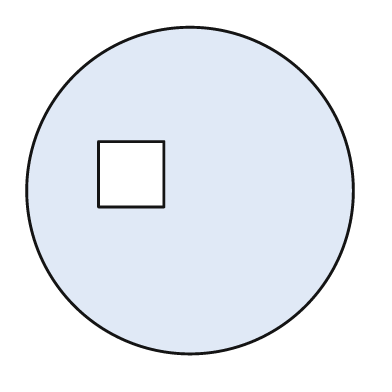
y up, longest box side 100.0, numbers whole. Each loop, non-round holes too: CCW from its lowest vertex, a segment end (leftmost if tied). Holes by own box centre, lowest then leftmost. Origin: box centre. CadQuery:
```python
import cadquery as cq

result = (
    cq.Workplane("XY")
    .moveTo(0.0, 0.0)
    .circle(50.0)
    .moveTo(-28.0, -5.0)
    .lineTo(-8.0, -5.0)
    .lineTo(-8.0, 15.0)
    .lineTo(-28.0, 15.0)
    .close()
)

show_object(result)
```